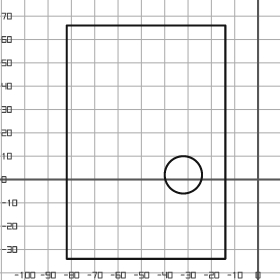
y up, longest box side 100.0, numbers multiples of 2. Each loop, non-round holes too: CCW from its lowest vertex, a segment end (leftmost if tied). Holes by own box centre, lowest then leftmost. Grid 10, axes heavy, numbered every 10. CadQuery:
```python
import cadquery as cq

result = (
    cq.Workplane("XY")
    .moveTo(-82.0, -34.0)
    .lineTo(-14.0, -34.0)
    .lineTo(-14.0, 66.0)
    .lineTo(-82.0, 66.0)
    .close()
    .moveTo(-32.0, 2.0)
    .circle(8.0)
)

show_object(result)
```